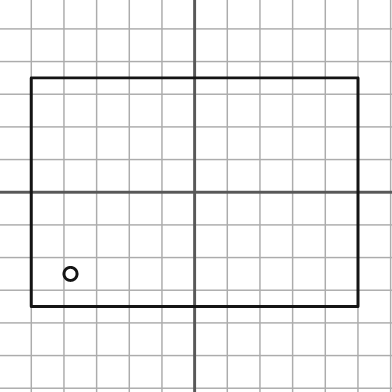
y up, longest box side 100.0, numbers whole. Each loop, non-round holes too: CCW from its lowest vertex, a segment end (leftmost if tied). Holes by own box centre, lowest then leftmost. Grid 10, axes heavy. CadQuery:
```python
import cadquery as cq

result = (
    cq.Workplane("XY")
    .moveTo(-50.0, -35.0)
    .lineTo(50.0, -35.0)
    .lineTo(50.0, 35.0)
    .lineTo(-50.0, 35.0)
    .close()
    .moveTo(-38.0, -25.0)
    .circle(2.0)
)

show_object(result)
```